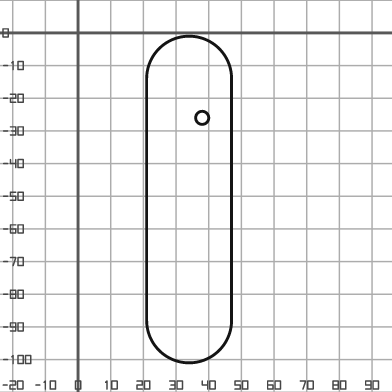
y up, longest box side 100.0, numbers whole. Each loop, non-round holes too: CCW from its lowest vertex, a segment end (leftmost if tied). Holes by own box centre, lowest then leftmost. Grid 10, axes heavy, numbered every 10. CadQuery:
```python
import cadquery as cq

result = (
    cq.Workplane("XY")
    .moveTo(21.0, -88.0)
    .threePointArc((34.0, -101.0), (47.0, -88.0))
    .lineTo(47.0, -14.0)
    .threePointArc((34.0, -1.0), (21.0, -14.0))
    .close()
    .moveTo(38.0, -26.0)
    .circle(2.0)
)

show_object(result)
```